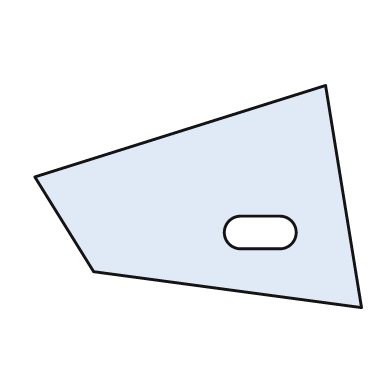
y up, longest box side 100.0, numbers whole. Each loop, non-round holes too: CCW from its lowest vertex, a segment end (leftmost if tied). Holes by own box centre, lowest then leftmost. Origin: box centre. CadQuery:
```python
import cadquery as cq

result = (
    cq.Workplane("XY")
    .moveTo(50.0, -34.0)
    .lineTo(39.0, 34.0)
    .lineTo(-50.0, 6.0)
    .lineTo(-32.0, -23.0)
    .close()
    .moveTo(13.0, -16.0)
    .lineTo(25.0, -16.0)
    .threePointArc((30.0, -11.0), (25.0, -6.0))
    .lineTo(13.0, -6.0)
    .threePointArc((8.0, -11.0), (13.0, -16.0))
    .close()
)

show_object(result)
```